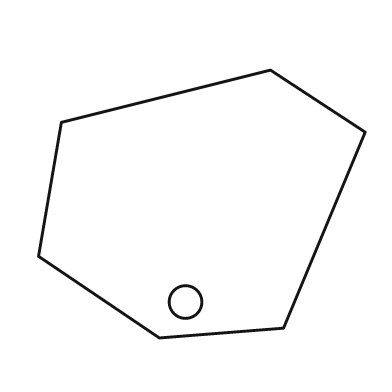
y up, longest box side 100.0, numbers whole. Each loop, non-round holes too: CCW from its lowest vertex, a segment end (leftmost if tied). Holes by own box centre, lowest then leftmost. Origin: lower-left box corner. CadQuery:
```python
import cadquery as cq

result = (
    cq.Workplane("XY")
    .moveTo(37.0, 0.0)
    .lineTo(75.0, 3.0)
    .lineTo(100.0, 63.0)
    .lineTo(71.0, 82.0)
    .lineTo(7.0, 66.0)
    .lineTo(0.0, 25.0)
    .close()
    .moveTo(45.0, 11.0)
    .circle(5.0)
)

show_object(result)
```